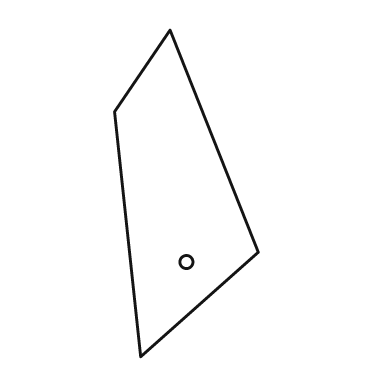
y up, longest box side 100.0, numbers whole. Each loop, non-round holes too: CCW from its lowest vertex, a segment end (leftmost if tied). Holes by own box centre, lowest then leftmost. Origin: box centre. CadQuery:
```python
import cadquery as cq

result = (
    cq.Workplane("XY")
    .moveTo(-14.0, -50.0)
    .lineTo(22.0, -18.0)
    .lineTo(-5.0, 50.0)
    .lineTo(-22.0, 25.0)
    .close()
    .moveTo(0.0, -21.0)
    .circle(2.0)
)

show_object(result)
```